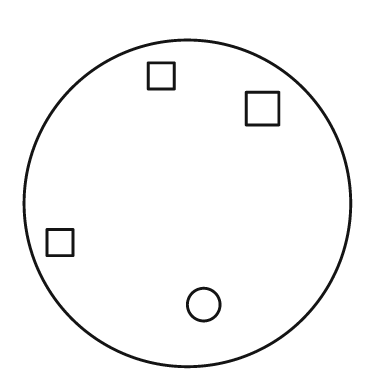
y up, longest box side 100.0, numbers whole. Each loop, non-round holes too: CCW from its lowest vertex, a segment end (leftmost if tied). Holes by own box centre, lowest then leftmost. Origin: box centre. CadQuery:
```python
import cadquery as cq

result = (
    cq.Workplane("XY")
    .moveTo(0.0, 0.0)
    .circle(50.0)
    .moveTo(5.0, -31.0)
    .circle(5.0)
    .moveTo(-43.0, -16.0)
    .lineTo(-35.0, -16.0)
    .lineTo(-35.0, -8.0)
    .lineTo(-43.0, -8.0)
    .close()
    .moveTo(18.0, 24.0)
    .lineTo(28.0, 24.0)
    .lineTo(28.0, 34.0)
    .lineTo(18.0, 34.0)
    .close()
    .moveTo(-12.0, 35.0)
    .lineTo(-4.0, 35.0)
    .lineTo(-4.0, 43.0)
    .lineTo(-12.0, 43.0)
    .close()
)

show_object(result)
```